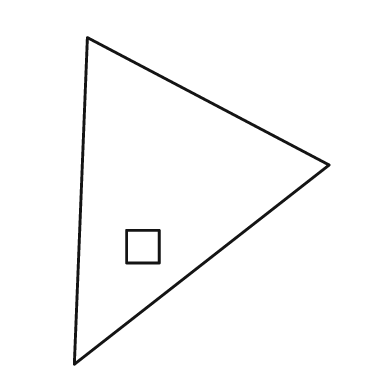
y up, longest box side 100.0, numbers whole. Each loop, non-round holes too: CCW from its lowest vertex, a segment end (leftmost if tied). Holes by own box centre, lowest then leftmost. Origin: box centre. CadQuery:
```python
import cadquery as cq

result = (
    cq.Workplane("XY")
    .moveTo(-39.0, -50.0)
    .lineTo(39.0, 11.0)
    .lineTo(-35.0, 50.0)
    .close()
    .moveTo(-23.0, -19.0)
    .lineTo(-13.0, -19.0)
    .lineTo(-13.0, -9.0)
    .lineTo(-23.0, -9.0)
    .close()
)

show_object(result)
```